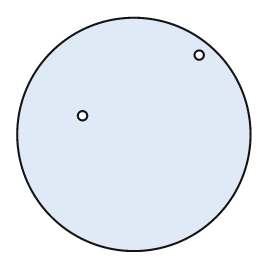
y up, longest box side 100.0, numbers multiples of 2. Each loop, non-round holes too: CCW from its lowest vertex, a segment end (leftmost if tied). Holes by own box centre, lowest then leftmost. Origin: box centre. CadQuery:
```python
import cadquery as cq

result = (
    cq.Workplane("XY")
    .moveTo(0.0, 0.0)
    .circle(50.0)
    .moveTo(-22.0, 8.0)
    .circle(2.0)
    .moveTo(28.0, 34.0)
    .circle(2.0)
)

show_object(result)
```